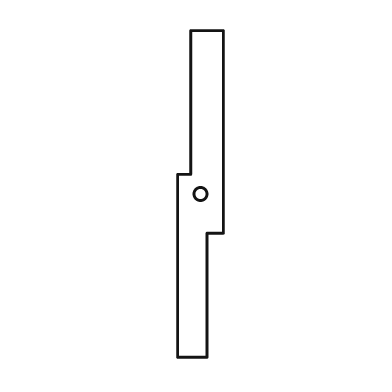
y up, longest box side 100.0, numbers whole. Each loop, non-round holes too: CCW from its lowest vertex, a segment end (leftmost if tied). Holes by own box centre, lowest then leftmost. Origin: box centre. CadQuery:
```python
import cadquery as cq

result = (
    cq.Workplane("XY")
    .moveTo(-7.0, -50.0)
    .lineTo(2.0, -50.0)
    .lineTo(2.0, -12.0)
    .lineTo(7.0, -12.0)
    .lineTo(7.0, 50.0)
    .lineTo(-3.0, 50.0)
    .lineTo(-3.0, 6.0)
    .lineTo(-7.0, 6.0)
    .close()
    .moveTo(0.0, 0.0)
    .circle(2.0)
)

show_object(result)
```